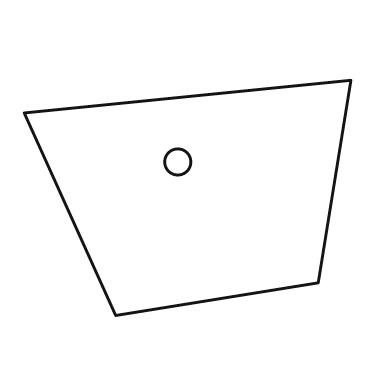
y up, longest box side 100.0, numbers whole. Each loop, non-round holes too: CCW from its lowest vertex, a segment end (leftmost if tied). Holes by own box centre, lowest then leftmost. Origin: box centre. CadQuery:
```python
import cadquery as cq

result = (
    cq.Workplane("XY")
    .moveTo(-22.0, -36.0)
    .lineTo(40.0, -26.0)
    .lineTo(50.0, 36.0)
    .lineTo(-50.0, 26.0)
    .close()
    .moveTo(-3.0, 11.0)
    .circle(4.0)
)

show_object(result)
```